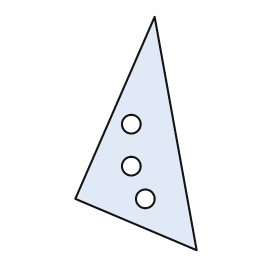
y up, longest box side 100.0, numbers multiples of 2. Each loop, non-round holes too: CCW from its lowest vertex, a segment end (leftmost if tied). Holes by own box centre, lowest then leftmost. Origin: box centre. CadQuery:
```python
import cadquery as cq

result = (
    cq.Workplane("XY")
    .moveTo(26.0, -50.0)
    .lineTo(8.0, 50.0)
    .lineTo(-26.0, -28.0)
    .close()
    .moveTo(4.0, -28.0)
    .circle(4.0)
    .moveTo(-2.0, -14.0)
    .circle(4.0)
    .moveTo(-2.0, 4.0)
    .circle(4.0)
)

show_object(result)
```